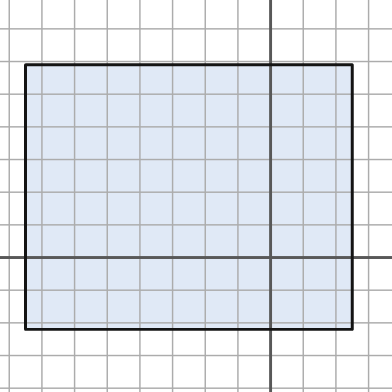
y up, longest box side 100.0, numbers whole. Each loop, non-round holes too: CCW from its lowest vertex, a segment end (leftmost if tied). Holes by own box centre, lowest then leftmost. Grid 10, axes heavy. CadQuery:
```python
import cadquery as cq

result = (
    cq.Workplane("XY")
    .moveTo(-75.0, -22.0)
    .lineTo(25.0, -22.0)
    .lineTo(25.0, 59.0)
    .lineTo(-75.0, 59.0)
    .close()
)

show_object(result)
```